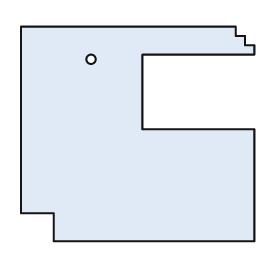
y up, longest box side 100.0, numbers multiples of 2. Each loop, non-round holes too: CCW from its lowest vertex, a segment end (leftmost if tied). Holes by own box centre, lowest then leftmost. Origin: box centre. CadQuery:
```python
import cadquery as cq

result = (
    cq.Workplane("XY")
    .moveTo(-36.0, -46.0)
    .lineTo(50.0, -46.0)
    .lineTo(50.0, 2.0)
    .lineTo(2.0, 2.0)
    .lineTo(2.0, 34.0)
    .lineTo(50.0, 34.0)
    .lineTo(50.0, 38.0)
    .lineTo(46.0, 38.0)
    .lineTo(46.0, 42.0)
    .lineTo(42.0, 42.0)
    .lineTo(42.0, 46.0)
    .lineTo(-50.0, 46.0)
    .lineTo(-50.0, -34.0)
    .lineTo(-36.0, -34.0)
    .close()
    .moveTo(-20.0, 32.0)
    .circle(2.0)
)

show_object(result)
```